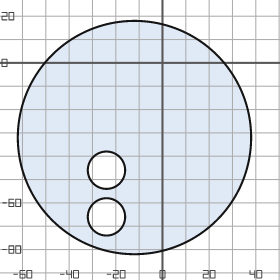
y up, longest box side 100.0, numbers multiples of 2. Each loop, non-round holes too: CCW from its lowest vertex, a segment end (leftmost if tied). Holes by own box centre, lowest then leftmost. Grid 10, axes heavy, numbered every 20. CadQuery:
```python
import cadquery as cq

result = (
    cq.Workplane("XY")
    .moveTo(-12.0, -32.0)
    .circle(50.0)
    .moveTo(-24.0, -66.0)
    .circle(8.0)
    .moveTo(-24.0, -46.0)
    .circle(8.0)
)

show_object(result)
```